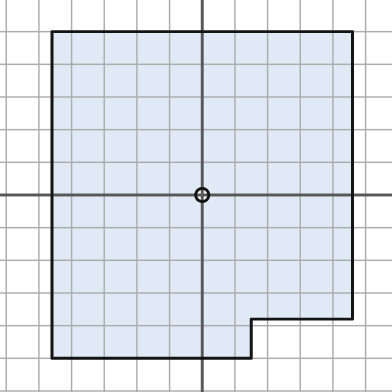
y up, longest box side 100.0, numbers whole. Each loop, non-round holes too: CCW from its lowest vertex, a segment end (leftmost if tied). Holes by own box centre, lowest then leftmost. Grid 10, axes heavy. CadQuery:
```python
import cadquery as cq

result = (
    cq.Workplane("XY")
    .moveTo(-46.0, -50.0)
    .lineTo(15.0, -50.0)
    .lineTo(15.0, -38.0)
    .lineTo(46.0, -38.0)
    .lineTo(46.0, 50.0)
    .lineTo(-46.0, 50.0)
    .close()
    .moveTo(0.0, 0.0)
    .circle(2.0)
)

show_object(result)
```